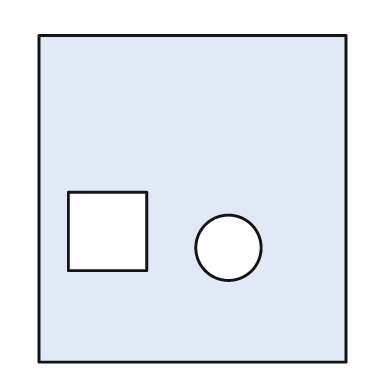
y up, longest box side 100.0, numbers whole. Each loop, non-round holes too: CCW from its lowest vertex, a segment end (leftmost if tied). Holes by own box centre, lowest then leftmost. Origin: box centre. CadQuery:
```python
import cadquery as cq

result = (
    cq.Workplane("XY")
    .moveTo(-47.0, -50.0)
    .lineTo(47.0, -50.0)
    .lineTo(47.0, 50.0)
    .lineTo(-47.0, 50.0)
    .close()
    .moveTo(11.0, -15.0)
    .circle(10.0)
    .moveTo(-38.0, -22.0)
    .lineTo(-14.0, -22.0)
    .lineTo(-14.0, 2.0)
    .lineTo(-38.0, 2.0)
    .close()
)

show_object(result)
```